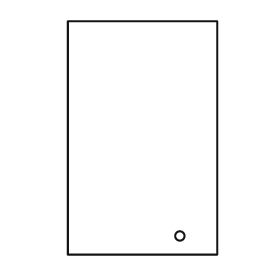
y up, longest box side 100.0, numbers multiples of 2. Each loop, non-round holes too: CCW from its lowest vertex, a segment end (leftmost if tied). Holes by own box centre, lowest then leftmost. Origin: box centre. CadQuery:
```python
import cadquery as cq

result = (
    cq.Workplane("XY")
    .moveTo(-32.0, -50.0)
    .lineTo(32.0, -50.0)
    .lineTo(32.0, 50.0)
    .lineTo(-32.0, 50.0)
    .close()
    .moveTo(16.0, -42.0)
    .circle(2.0)
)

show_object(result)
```